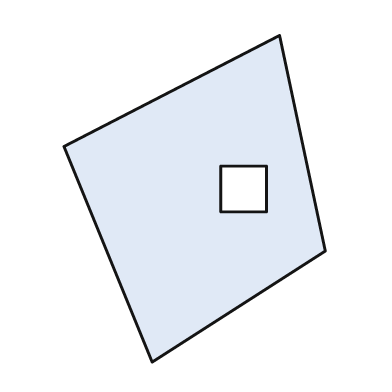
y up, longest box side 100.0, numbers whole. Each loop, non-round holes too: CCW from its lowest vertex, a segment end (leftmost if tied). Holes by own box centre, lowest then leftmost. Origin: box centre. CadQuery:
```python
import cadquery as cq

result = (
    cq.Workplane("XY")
    .moveTo(-13.0, -50.0)
    .lineTo(40.0, -16.0)
    .lineTo(26.0, 50.0)
    .lineTo(-40.0, 16.0)
    .close()
    .moveTo(8.0, -4.0)
    .lineTo(22.0, -4.0)
    .lineTo(22.0, 10.0)
    .lineTo(8.0, 10.0)
    .close()
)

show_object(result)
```